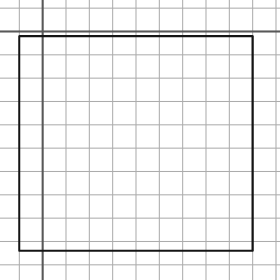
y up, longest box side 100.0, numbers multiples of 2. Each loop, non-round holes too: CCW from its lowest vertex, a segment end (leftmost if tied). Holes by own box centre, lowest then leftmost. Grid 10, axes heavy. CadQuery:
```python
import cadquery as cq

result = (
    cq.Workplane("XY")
    .moveTo(-10.0, -94.0)
    .lineTo(90.0, -94.0)
    .lineTo(90.0, -2.0)
    .lineTo(-10.0, -2.0)
    .close()
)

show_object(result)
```